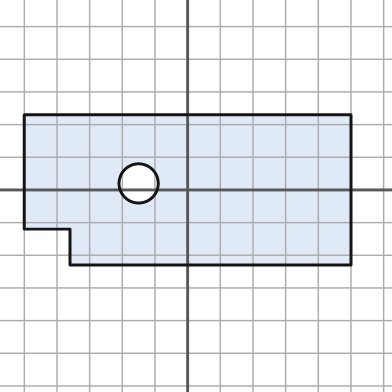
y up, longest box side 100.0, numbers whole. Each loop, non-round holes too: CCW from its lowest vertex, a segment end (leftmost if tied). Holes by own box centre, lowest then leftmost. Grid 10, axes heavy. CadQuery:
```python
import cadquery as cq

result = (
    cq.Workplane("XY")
    .moveTo(-36.0, -23.0)
    .lineTo(50.0, -23.0)
    .lineTo(50.0, 23.0)
    .lineTo(-50.0, 23.0)
    .lineTo(-50.0, -12.0)
    .lineTo(-36.0, -12.0)
    .close()
    .moveTo(-15.0, 2.0)
    .circle(6.0)
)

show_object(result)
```